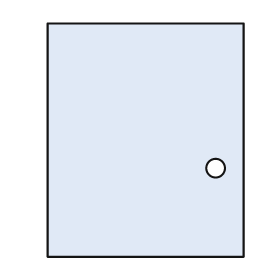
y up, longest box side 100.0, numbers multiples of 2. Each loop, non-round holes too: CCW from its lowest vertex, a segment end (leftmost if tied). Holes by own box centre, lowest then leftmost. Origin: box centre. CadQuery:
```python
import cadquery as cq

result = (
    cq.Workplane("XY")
    .moveTo(-42.0, -50.0)
    .lineTo(42.0, -50.0)
    .lineTo(42.0, 50.0)
    .lineTo(-42.0, 50.0)
    .close()
    .moveTo(30.0, -12.0)
    .circle(4.0)
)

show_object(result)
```